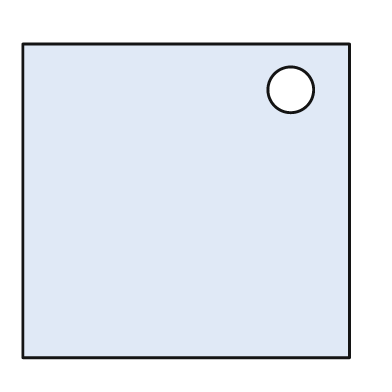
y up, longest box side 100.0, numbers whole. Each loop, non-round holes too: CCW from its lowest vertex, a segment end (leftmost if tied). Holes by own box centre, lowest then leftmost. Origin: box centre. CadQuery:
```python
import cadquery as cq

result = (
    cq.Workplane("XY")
    .moveTo(-50.0, -48.0)
    .lineTo(50.0, -48.0)
    .lineTo(50.0, 48.0)
    .lineTo(-50.0, 48.0)
    .close()
    .moveTo(32.0, 34.0)
    .circle(7.0)
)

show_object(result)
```